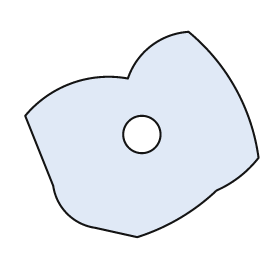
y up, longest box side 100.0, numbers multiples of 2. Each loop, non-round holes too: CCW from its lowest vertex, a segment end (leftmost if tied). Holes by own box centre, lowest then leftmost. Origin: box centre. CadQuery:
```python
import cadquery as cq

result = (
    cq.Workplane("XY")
    .moveTo(-2.0, -44.0)
    .threePointArc((16.0, -36.0), (32.0, -24.0))
    .threePointArc((42.0, -18.0), (50.0, -10.0))
    .threePointArc((40.0, 20.0), (20.0, 44.0))
    .threePointArc((4.0, 38.0), (-6.0, 24.0))
    .threePointArc((-30.0, 22.0), (-50.0, 8.0))
    .lineTo(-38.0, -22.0)
    .threePointArc((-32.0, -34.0), (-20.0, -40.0))
    .close()
    .moveTo(0.0, 0.0)
    .circle(8.0)
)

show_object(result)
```